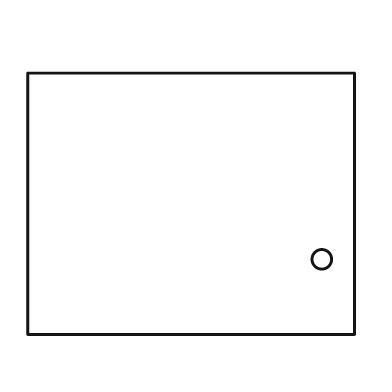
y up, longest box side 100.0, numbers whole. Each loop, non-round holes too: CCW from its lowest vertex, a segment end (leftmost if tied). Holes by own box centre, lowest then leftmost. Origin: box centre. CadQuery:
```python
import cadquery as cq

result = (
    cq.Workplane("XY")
    .moveTo(-50.0, -40.0)
    .lineTo(50.0, -40.0)
    .lineTo(50.0, 40.0)
    .lineTo(-50.0, 40.0)
    .close()
    .moveTo(40.0, -17.0)
    .circle(3.0)
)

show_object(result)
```